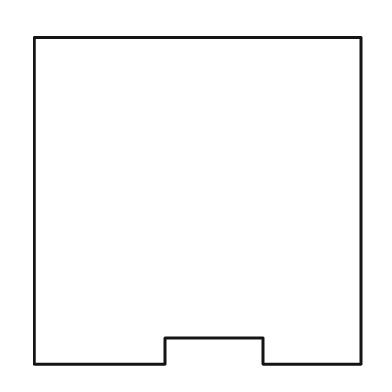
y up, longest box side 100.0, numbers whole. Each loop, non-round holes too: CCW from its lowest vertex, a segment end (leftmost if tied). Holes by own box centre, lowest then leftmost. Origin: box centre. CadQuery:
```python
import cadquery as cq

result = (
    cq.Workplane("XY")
    .moveTo(-50.0, -50.0)
    .lineTo(-10.0, -50.0)
    .lineTo(-10.0, -42.0)
    .lineTo(20.0, -42.0)
    .lineTo(20.0, -50.0)
    .lineTo(50.0, -50.0)
    .lineTo(50.0, 50.0)
    .lineTo(-50.0, 50.0)
    .close()
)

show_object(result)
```